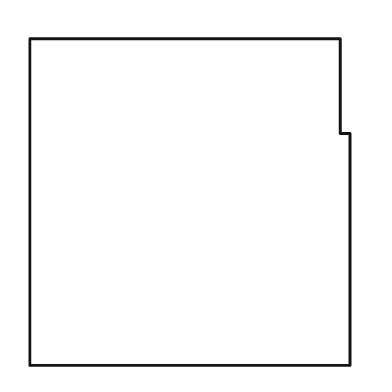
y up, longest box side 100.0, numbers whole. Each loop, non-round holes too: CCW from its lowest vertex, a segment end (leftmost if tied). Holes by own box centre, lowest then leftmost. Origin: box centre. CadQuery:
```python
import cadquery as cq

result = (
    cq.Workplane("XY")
    .moveTo(-49.0, -50.0)
    .lineTo(49.0, -50.0)
    .lineTo(49.0, 21.0)
    .lineTo(46.0, 21.0)
    .lineTo(46.0, 50.0)
    .lineTo(-49.0, 50.0)
    .close()
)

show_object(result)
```